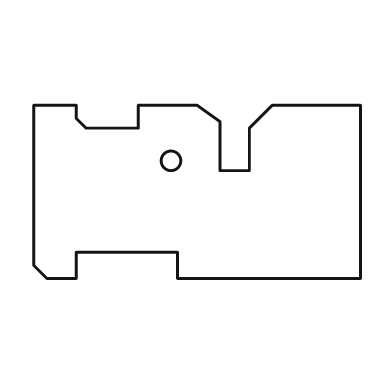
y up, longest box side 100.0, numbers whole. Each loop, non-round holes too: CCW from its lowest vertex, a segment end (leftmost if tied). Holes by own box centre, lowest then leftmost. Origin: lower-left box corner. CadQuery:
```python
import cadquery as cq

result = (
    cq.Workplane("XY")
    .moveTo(4.0, 0.0)
    .lineTo(13.0, 0.0)
    .lineTo(13.0, 8.0)
    .lineTo(44.0, 8.0)
    .lineTo(44.0, 0.0)
    .lineTo(100.0, 0.0)
    .lineTo(100.0, 53.0)
    .lineTo(73.0, 53.0)
    .lineTo(66.0, 46.0)
    .lineTo(66.0, 33.0)
    .lineTo(57.0, 33.0)
    .lineTo(57.0, 48.0)
    .lineTo(50.0, 53.0)
    .lineTo(32.0, 53.0)
    .lineTo(32.0, 46.0)
    .lineTo(16.0, 46.0)
    .lineTo(13.0, 49.0)
    .lineTo(13.0, 53.0)
    .lineTo(0.0, 53.0)
    .lineTo(0.0, 4.0)
    .close()
    .moveTo(42.0, 36.0)
    .circle(3.0)
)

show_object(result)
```